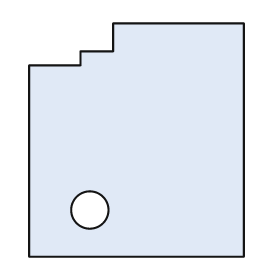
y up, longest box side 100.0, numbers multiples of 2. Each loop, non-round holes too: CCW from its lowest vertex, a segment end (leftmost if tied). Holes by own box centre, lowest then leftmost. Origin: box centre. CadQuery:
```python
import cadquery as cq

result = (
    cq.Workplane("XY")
    .moveTo(-46.0, -50.0)
    .lineTo(46.0, -50.0)
    .lineTo(46.0, 50.0)
    .lineTo(-10.0, 50.0)
    .lineTo(-10.0, 38.0)
    .lineTo(-24.0, 38.0)
    .lineTo(-24.0, 32.0)
    .lineTo(-46.0, 32.0)
    .close()
    .moveTo(-20.0, -30.0)
    .circle(8.0)
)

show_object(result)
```